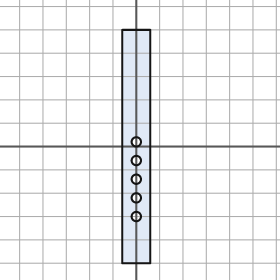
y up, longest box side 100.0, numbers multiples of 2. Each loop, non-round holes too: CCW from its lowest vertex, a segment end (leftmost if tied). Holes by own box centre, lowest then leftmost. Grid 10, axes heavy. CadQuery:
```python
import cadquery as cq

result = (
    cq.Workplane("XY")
    .moveTo(-6.0, -50.0)
    .lineTo(6.0, -50.0)
    .lineTo(6.0, 50.0)
    .lineTo(-6.0, 50.0)
    .close()
    .moveTo(0.0, -30.0)
    .circle(2.0)
    .moveTo(0.0, -22.0)
    .circle(2.0)
    .moveTo(0.0, -14.0)
    .circle(2.0)
    .moveTo(0.0, -6.0)
    .circle(2.0)
    .moveTo(0.0, 2.0)
    .circle(2.0)
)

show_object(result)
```